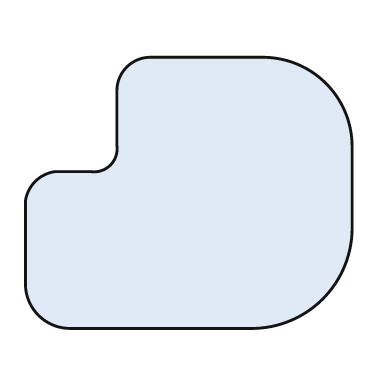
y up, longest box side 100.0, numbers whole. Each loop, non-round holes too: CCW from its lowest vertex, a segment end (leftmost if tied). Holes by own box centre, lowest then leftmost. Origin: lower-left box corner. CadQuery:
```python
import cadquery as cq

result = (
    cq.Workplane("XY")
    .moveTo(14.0, 0.0)
    .lineTo(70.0, 0.0)
    .threePointArc((91.0, 9.0), (100.0, 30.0))
    .lineTo(100.0, 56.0)
    .threePointArc((92.0, 75.0), (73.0, 83.0))
    .lineTo(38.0, 83.0)
    .threePointArc((31.0, 80.0), (28.0, 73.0))
    .lineTo(28.0, 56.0)
    .threePointArc((26.0, 50.0), (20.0, 48.0))
    .lineTo(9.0, 48.0)
    .threePointArc((3.0, 45.0), (0.0, 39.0))
    .lineTo(0.0, 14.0)
    .threePointArc((4.0, 4.0), (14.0, 0.0))
    .close()
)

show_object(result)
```